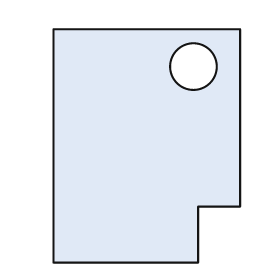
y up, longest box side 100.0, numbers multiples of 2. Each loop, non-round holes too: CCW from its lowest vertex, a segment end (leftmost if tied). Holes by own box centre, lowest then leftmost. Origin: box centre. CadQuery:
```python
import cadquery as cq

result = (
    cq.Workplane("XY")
    .moveTo(-40.0, -50.0)
    .lineTo(22.0, -50.0)
    .lineTo(22.0, -26.0)
    .lineTo(40.0, -26.0)
    .lineTo(40.0, 50.0)
    .lineTo(-40.0, 50.0)
    .close()
    .moveTo(20.0, 34.0)
    .circle(10.0)
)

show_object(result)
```